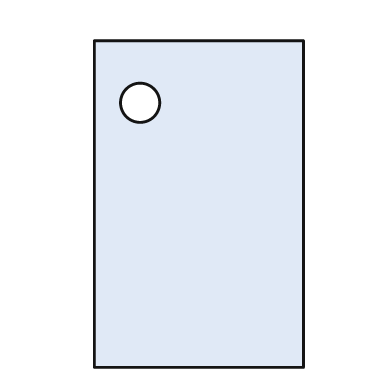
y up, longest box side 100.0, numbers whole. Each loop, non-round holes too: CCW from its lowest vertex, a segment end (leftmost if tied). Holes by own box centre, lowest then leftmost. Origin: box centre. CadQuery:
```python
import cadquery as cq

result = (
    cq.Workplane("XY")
    .moveTo(-32.0, -50.0)
    .lineTo(32.0, -50.0)
    .lineTo(32.0, 50.0)
    .lineTo(-32.0, 50.0)
    .close()
    .moveTo(-18.0, 31.0)
    .circle(6.0)
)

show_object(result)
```